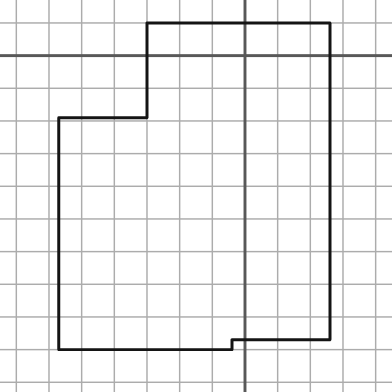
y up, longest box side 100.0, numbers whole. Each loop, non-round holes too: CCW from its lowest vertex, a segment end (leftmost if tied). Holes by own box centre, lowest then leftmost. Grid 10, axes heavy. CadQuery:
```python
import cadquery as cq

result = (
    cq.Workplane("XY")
    .moveTo(-57.0, -90.0)
    .lineTo(-4.0, -90.0)
    .lineTo(-4.0, -87.0)
    .lineTo(26.0, -87.0)
    .lineTo(26.0, 10.0)
    .lineTo(-30.0, 10.0)
    .lineTo(-30.0, -19.0)
    .lineTo(-57.0, -19.0)
    .close()
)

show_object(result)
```